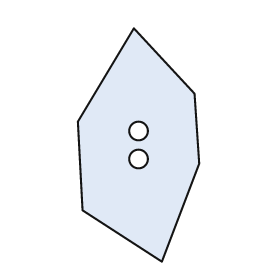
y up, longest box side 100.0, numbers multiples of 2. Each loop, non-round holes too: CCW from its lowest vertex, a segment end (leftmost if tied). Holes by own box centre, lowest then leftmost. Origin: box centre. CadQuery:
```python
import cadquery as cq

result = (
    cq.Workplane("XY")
    .moveTo(10.0, -50.0)
    .lineTo(26.0, -8.0)
    .lineTo(24.0, 22.0)
    .lineTo(-2.0, 50.0)
    .lineTo(-26.0, 10.0)
    .lineTo(-24.0, -28.0)
    .close()
    .moveTo(0.0, -6.0)
    .circle(4.0)
    .moveTo(0.0, 6.0)
    .circle(4.0)
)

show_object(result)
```